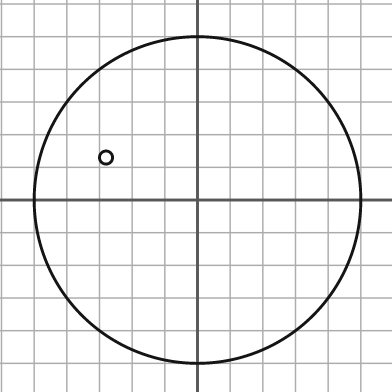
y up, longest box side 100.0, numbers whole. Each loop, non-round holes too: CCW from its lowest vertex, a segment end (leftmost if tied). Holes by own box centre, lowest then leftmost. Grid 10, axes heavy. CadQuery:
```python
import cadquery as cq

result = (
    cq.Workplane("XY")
    .moveTo(0.0, 0.0)
    .circle(50.0)
    .moveTo(-28.0, 13.0)
    .circle(2.0)
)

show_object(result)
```